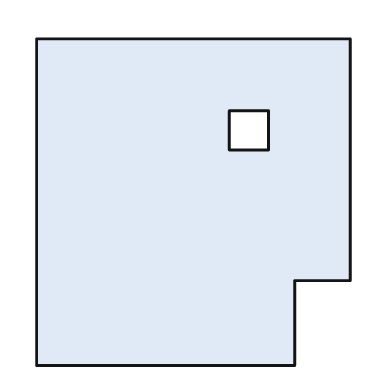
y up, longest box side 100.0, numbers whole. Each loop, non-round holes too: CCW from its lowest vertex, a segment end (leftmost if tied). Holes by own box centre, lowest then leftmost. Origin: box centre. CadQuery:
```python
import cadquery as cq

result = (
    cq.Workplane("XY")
    .moveTo(-48.0, -50.0)
    .lineTo(31.0, -50.0)
    .lineTo(31.0, -24.0)
    .lineTo(48.0, -24.0)
    .lineTo(48.0, 50.0)
    .lineTo(-48.0, 50.0)
    .close()
    .moveTo(11.0, 16.0)
    .lineTo(23.0, 16.0)
    .lineTo(23.0, 28.0)
    .lineTo(11.0, 28.0)
    .close()
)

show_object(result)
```